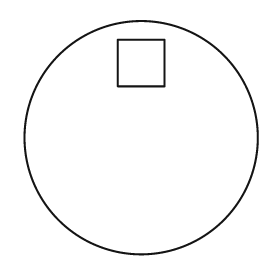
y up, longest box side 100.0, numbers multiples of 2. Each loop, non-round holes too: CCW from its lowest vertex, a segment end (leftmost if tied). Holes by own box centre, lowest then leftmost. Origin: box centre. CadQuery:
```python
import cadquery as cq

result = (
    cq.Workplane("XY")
    .moveTo(0.0, 0.0)
    .circle(50.0)
    .moveTo(-10.0, 22.0)
    .lineTo(10.0, 22.0)
    .lineTo(10.0, 42.0)
    .lineTo(-10.0, 42.0)
    .close()
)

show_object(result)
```